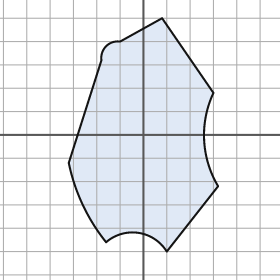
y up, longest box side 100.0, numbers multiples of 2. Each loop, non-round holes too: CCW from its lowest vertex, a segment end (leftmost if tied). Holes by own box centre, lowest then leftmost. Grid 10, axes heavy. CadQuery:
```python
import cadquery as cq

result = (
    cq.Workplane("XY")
    .moveTo(10.0, -50.0)
    .lineTo(32.0, -22.0)
    .threePointArc((26.0, -2.0), (30.0, 18.0))
    .lineTo(8.0, 50.0)
    .lineTo(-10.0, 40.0)
    .threePointArc((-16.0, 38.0), (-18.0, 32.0))
    .lineTo(-32.0, -12.0)
    .threePointArc((-26.0, -30.0), (-16.0, -46.0))
    .threePointArc((-2.0, -42.0), (10.0, -50.0))
    .close()
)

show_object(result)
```